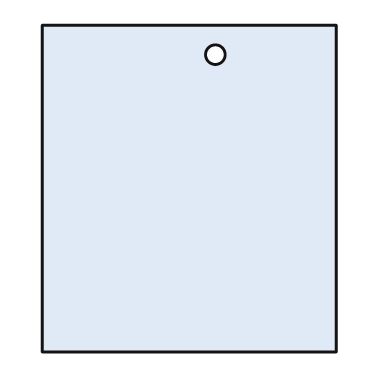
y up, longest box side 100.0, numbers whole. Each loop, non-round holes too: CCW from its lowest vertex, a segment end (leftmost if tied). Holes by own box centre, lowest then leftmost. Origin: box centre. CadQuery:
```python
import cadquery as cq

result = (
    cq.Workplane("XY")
    .moveTo(-45.0, -50.0)
    .lineTo(45.0, -50.0)
    .lineTo(45.0, 50.0)
    .lineTo(-45.0, 50.0)
    .close()
    .moveTo(8.0, 41.0)
    .circle(3.0)
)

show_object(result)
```